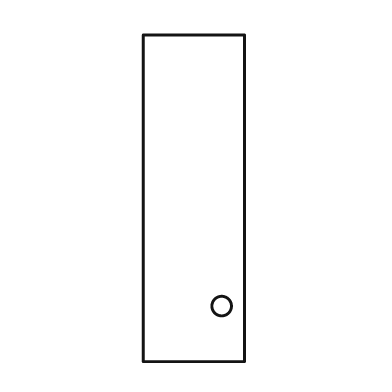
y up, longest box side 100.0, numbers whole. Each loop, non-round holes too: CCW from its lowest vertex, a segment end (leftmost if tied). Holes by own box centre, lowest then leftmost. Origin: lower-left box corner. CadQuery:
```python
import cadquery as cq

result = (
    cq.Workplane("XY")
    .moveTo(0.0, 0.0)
    .lineTo(31.0, 0.0)
    .lineTo(31.0, 100.0)
    .lineTo(0.0, 100.0)
    .close()
    .moveTo(24.0, 17.0)
    .circle(3.0)
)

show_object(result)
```